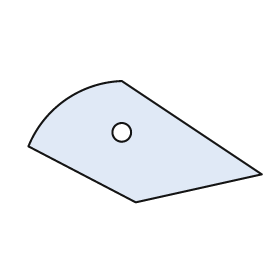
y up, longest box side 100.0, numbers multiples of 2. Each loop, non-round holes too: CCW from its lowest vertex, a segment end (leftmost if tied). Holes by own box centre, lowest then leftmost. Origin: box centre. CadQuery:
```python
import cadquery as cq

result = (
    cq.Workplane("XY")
    .moveTo(-4.0, -26.0)
    .lineTo(50.0, -14.0)
    .lineTo(-10.0, 26.0)
    .threePointArc((-34.0, 18.0), (-50.0, -2.0))
    .close()
    .moveTo(-10.0, 4.0)
    .circle(4.0)
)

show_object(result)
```